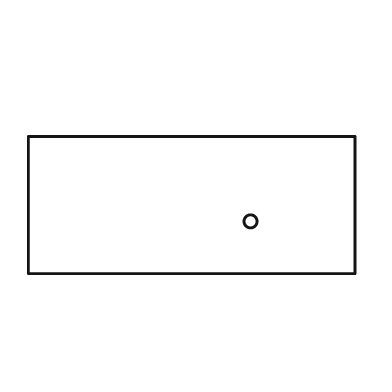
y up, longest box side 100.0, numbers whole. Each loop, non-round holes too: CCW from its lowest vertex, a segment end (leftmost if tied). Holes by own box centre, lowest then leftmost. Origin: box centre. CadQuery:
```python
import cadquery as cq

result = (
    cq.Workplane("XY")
    .moveTo(-50.0, -21.0)
    .lineTo(50.0, -21.0)
    .lineTo(50.0, 21.0)
    .lineTo(-50.0, 21.0)
    .close()
    .moveTo(18.0, -5.0)
    .circle(2.0)
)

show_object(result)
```